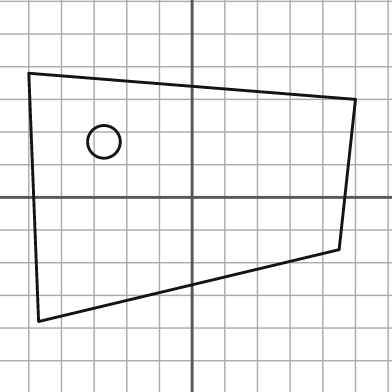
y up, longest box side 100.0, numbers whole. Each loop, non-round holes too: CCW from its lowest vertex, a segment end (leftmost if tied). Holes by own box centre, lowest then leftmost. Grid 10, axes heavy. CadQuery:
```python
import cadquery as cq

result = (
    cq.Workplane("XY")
    .moveTo(-47.0, -38.0)
    .lineTo(45.0, -16.0)
    .lineTo(50.0, 30.0)
    .lineTo(-50.0, 38.0)
    .close()
    .moveTo(-27.0, 17.0)
    .circle(5.0)
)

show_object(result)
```